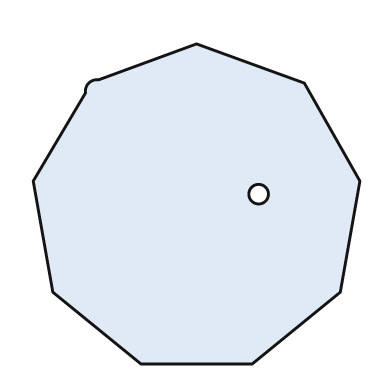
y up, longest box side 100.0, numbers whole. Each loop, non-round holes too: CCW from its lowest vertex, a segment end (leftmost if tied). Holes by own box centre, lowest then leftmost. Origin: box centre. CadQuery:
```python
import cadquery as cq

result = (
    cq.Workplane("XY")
    .moveTo(-17.0, -49.0)
    .lineTo(17.0, -49.0)
    .lineTo(44.0, -27.0)
    .lineTo(50.0, 7.0)
    .lineTo(33.0, 37.0)
    .lineTo(0.0, 49.0)
    .lineTo(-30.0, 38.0)
    .threePointArc((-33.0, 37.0), (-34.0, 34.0))
    .lineTo(-50.0, 7.0)
    .lineTo(-44.0, -27.0)
    .close()
    .moveTo(19.0, 3.0)
    .circle(3.0)
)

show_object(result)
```